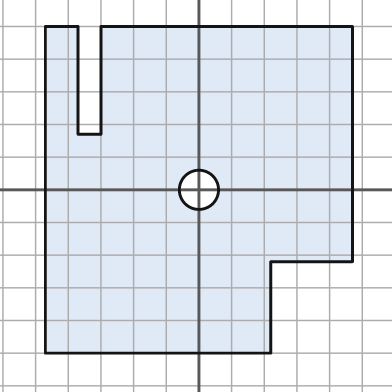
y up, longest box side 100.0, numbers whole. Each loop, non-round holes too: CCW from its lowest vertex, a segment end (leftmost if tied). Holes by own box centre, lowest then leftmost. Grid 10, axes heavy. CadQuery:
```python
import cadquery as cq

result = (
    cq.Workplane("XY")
    .moveTo(-47.0, -50.0)
    .lineTo(22.0, -50.0)
    .lineTo(22.0, -22.0)
    .lineTo(47.0, -22.0)
    .lineTo(47.0, 50.0)
    .lineTo(-30.0, 50.0)
    .lineTo(-30.0, 17.0)
    .lineTo(-37.0, 17.0)
    .lineTo(-37.0, 50.0)
    .lineTo(-47.0, 50.0)
    .close()
    .moveTo(0.0, 0.0)
    .circle(6.0)
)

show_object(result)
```